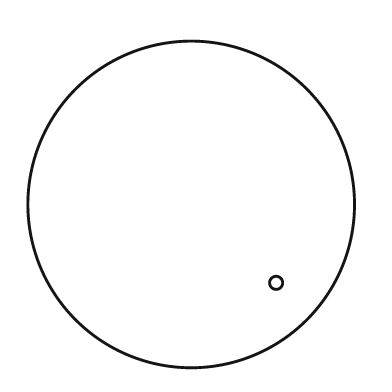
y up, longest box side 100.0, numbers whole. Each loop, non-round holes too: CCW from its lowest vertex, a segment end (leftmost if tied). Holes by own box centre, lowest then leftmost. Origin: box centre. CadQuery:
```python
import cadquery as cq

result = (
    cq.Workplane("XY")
    .moveTo(0.0, 0.0)
    .circle(50.0)
    .moveTo(26.0, -24.0)
    .circle(2.0)
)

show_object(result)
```